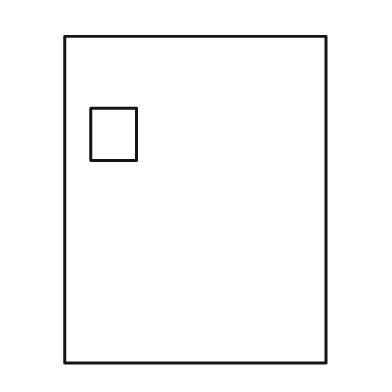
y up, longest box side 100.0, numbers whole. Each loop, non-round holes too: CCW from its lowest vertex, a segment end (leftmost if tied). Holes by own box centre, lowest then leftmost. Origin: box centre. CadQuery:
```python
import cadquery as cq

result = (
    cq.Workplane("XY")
    .moveTo(-40.0, -50.0)
    .lineTo(40.0, -50.0)
    .lineTo(40.0, 50.0)
    .lineTo(-40.0, 50.0)
    .close()
    .moveTo(-32.0, 12.0)
    .lineTo(-18.0, 12.0)
    .lineTo(-18.0, 28.0)
    .lineTo(-32.0, 28.0)
    .close()
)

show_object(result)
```